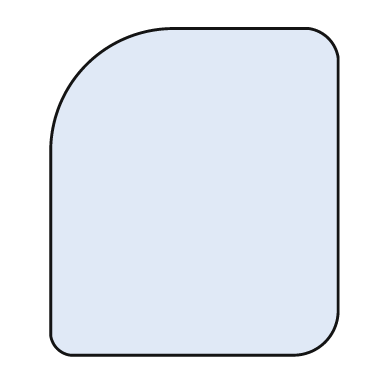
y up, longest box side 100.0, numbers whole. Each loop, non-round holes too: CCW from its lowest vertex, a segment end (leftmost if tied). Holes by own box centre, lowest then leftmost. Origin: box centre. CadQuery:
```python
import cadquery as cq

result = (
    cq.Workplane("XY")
    .moveTo(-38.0, -50.0)
    .lineTo(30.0, -50.0)
    .threePointArc((40.0, -46.0), (44.0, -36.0))
    .lineTo(44.0, 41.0)
    .threePointArc((41.0, 47.0), (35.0, 50.0))
    .lineTo(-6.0, 50.0)
    .threePointArc((-33.0, 39.0), (-44.0, 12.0))
    .lineTo(-44.0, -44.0)
    .threePointArc((-42.0, -48.0), (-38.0, -50.0))
    .close()
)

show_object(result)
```